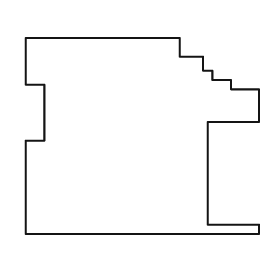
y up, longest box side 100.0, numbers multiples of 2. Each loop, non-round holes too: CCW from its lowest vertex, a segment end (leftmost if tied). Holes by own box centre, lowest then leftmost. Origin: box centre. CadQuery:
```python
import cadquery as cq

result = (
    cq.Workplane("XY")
    .moveTo(-50.0, -42.0)
    .lineTo(50.0, -42.0)
    .lineTo(50.0, -38.0)
    .lineTo(28.0, -38.0)
    .lineTo(28.0, 6.0)
    .lineTo(50.0, 6.0)
    .lineTo(50.0, 20.0)
    .lineTo(38.0, 20.0)
    .lineTo(38.0, 24.0)
    .lineTo(30.0, 24.0)
    .lineTo(30.0, 28.0)
    .lineTo(26.0, 28.0)
    .lineTo(26.0, 34.0)
    .lineTo(16.0, 34.0)
    .lineTo(16.0, 42.0)
    .lineTo(-50.0, 42.0)
    .lineTo(-50.0, 22.0)
    .lineTo(-42.0, 22.0)
    .lineTo(-42.0, -2.0)
    .lineTo(-50.0, -2.0)
    .close()
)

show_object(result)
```